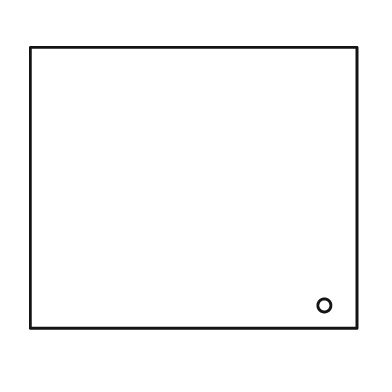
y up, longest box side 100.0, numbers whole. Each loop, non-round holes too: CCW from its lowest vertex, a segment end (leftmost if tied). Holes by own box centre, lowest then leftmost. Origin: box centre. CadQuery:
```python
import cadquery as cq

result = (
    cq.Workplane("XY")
    .moveTo(-50.0, -43.0)
    .lineTo(50.0, -43.0)
    .lineTo(50.0, 43.0)
    .lineTo(-50.0, 43.0)
    .close()
    .moveTo(40.0, -36.0)
    .circle(2.0)
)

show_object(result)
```